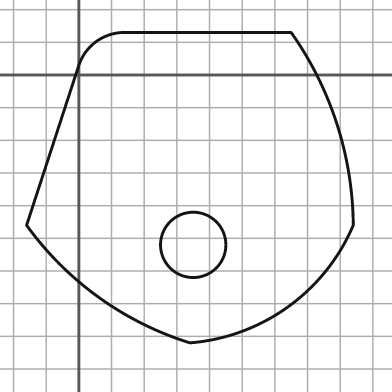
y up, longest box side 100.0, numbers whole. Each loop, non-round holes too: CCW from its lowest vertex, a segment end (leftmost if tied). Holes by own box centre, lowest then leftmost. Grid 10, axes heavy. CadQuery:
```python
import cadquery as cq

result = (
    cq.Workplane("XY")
    .moveTo(34.0, -82.0)
    .threePointArc((64.0, -71.0), (84.0, -46.0))
    .threePointArc((79.0, -15.0), (65.0, 13.0))
    .lineTo(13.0, 13.0)
    .threePointArc((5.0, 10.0), (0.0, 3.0))
    .lineTo(-16.0, -46.0)
    .threePointArc((6.0, -68.0), (34.0, -82.0))
    .close()
    .moveTo(35.0, -52.0)
    .circle(10.0)
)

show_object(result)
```